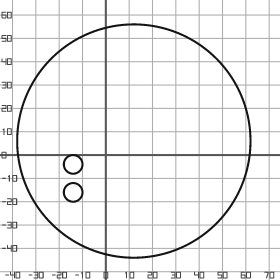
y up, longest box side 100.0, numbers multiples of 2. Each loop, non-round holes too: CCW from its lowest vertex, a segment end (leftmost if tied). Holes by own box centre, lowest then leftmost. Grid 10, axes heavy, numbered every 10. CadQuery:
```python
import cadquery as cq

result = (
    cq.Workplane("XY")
    .moveTo(12.0, 6.0)
    .circle(50.0)
    .moveTo(-14.0, -16.0)
    .circle(4.0)
    .moveTo(-14.0, -4.0)
    .circle(4.0)
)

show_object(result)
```